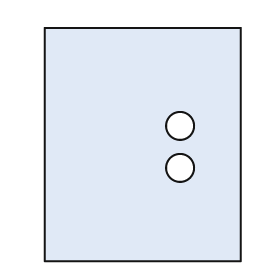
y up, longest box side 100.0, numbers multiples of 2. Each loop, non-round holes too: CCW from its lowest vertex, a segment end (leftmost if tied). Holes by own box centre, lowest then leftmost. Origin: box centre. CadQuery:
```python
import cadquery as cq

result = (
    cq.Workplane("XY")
    .moveTo(-42.0, -50.0)
    .lineTo(42.0, -50.0)
    .lineTo(42.0, 50.0)
    .lineTo(-42.0, 50.0)
    .close()
    .moveTo(16.0, -10.0)
    .circle(6.0)
    .moveTo(16.0, 8.0)
    .circle(6.0)
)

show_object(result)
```